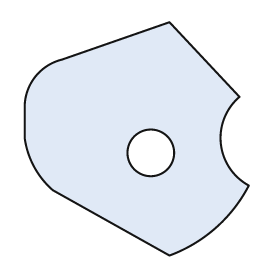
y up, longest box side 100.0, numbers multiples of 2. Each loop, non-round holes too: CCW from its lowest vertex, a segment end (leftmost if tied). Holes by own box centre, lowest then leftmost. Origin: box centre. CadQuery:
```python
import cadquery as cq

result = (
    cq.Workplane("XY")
    .moveTo(14.0, -50.0)
    .threePointArc((34.0, -38.0), (48.0, -20.0))
    .threePointArc((36.0, -2.0), (44.0, 18.0))
    .lineTo(14.0, 50.0)
    .lineTo(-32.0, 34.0)
    .threePointArc((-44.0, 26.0), (-48.0, 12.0))
    .lineTo(-48.0, 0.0)
    .threePointArc((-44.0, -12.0), (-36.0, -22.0))
    .close()
    .moveTo(6.0, -6.0)
    .circle(10.0)
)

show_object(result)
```